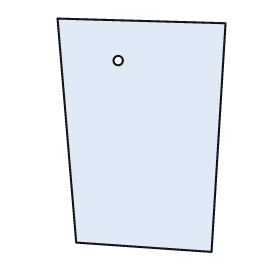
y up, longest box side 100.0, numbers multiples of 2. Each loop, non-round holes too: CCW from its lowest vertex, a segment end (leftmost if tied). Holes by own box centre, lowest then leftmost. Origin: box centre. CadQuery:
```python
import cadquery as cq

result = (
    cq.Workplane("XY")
    .moveTo(30.0, -50.0)
    .lineTo(36.0, 48.0)
    .lineTo(-36.0, 50.0)
    .lineTo(-28.0, -46.0)
    .close()
    .moveTo(-10.0, 32.0)
    .circle(2.0)
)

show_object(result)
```